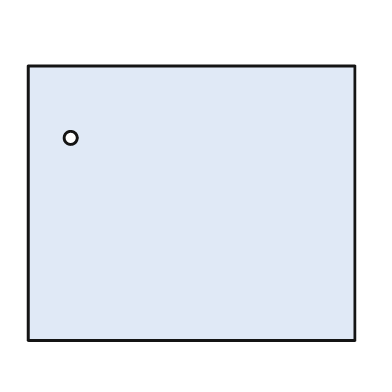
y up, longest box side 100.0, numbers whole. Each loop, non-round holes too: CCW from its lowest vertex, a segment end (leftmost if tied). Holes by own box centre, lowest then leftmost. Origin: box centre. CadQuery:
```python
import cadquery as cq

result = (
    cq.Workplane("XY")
    .moveTo(-50.0, -42.0)
    .lineTo(50.0, -42.0)
    .lineTo(50.0, 42.0)
    .lineTo(-50.0, 42.0)
    .close()
    .moveTo(-37.0, 20.0)
    .circle(2.0)
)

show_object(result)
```